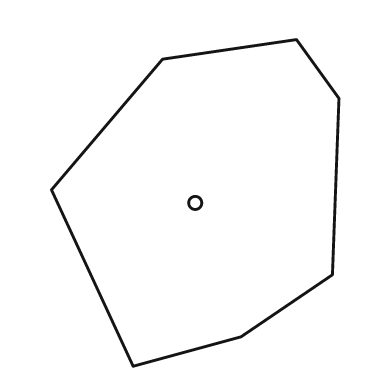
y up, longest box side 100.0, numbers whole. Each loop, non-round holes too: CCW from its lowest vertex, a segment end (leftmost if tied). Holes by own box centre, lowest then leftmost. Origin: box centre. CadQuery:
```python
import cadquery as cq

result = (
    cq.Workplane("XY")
    .moveTo(-19.0, -50.0)
    .lineTo(14.0, -41.0)
    .lineTo(42.0, -22.0)
    .lineTo(44.0, 32.0)
    .lineTo(31.0, 50.0)
    .lineTo(-10.0, 44.0)
    .lineTo(-44.0, 4.0)
    .close()
    .moveTo(0.0, 0.0)
    .circle(2.0)
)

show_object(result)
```